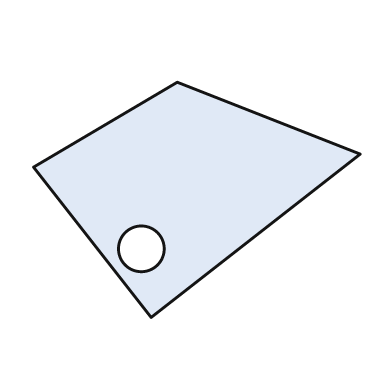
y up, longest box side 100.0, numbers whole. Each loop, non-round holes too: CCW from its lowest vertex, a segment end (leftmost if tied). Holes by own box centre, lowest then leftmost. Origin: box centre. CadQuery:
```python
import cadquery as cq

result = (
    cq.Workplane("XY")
    .moveTo(-14.0, -36.0)
    .lineTo(50.0, 14.0)
    .lineTo(-6.0, 36.0)
    .lineTo(-50.0, 10.0)
    .close()
    .moveTo(-17.0, -15.0)
    .circle(7.0)
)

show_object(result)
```